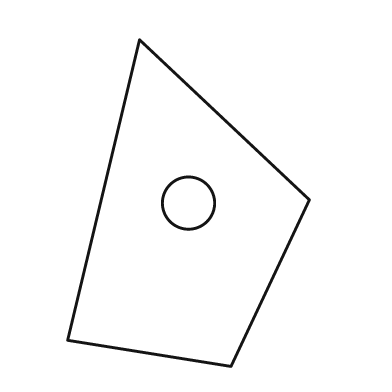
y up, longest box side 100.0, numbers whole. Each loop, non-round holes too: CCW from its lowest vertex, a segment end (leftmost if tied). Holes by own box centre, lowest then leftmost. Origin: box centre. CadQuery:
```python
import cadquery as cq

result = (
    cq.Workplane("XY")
    .moveTo(13.0, -50.0)
    .lineTo(37.0, 1.0)
    .lineTo(-15.0, 50.0)
    .lineTo(-37.0, -42.0)
    .close()
    .moveTo(0.0, 0.0)
    .circle(8.0)
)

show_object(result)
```